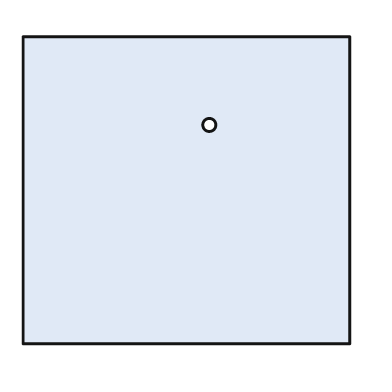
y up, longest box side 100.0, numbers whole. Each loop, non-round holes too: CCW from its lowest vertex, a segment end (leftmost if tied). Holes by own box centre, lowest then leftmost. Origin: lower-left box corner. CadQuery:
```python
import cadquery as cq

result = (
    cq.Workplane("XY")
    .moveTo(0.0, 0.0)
    .lineTo(100.0, 0.0)
    .lineTo(100.0, 94.0)
    .lineTo(0.0, 94.0)
    .close()
    .moveTo(57.0, 67.0)
    .circle(2.0)
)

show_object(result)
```